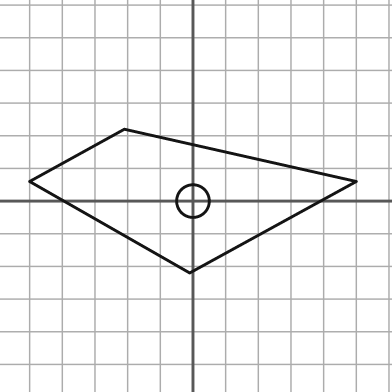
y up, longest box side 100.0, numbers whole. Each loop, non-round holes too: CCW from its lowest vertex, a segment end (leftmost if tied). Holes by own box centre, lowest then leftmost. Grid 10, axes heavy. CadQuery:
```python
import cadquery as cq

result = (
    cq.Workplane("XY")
    .moveTo(-1.0, -22.0)
    .lineTo(50.0, 6.0)
    .lineTo(-21.0, 22.0)
    .lineTo(-50.0, 6.0)
    .close()
    .moveTo(0.0, 0.0)
    .circle(5.0)
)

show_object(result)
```